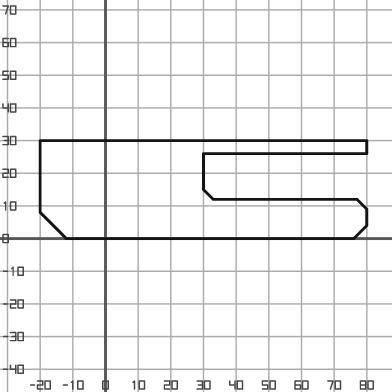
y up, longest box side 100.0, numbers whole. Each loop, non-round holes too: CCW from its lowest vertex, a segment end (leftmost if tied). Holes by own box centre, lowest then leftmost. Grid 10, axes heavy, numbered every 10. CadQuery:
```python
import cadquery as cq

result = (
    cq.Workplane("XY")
    .moveTo(-12.0, 0.0)
    .lineTo(76.0, 0.0)
    .lineTo(80.0, 4.0)
    .lineTo(80.0, 9.0)
    .lineTo(77.0, 12.0)
    .lineTo(33.0, 12.0)
    .lineTo(30.0, 15.0)
    .lineTo(30.0, 26.0)
    .lineTo(80.0, 26.0)
    .lineTo(80.0, 30.0)
    .lineTo(-20.0, 30.0)
    .lineTo(-20.0, 8.0)
    .close()
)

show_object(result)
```